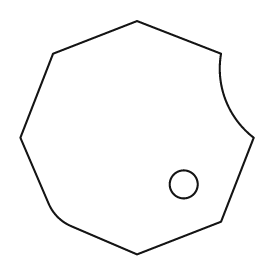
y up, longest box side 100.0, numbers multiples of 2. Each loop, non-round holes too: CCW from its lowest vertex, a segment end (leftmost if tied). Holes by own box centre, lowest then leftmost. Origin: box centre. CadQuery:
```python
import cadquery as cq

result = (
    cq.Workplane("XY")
    .moveTo(0.0, -50.0)
    .lineTo(36.0, -36.0)
    .lineTo(50.0, 0.0)
    .threePointArc((38.0, 16.0), (36.0, 36.0))
    .lineTo(0.0, 50.0)
    .lineTo(-36.0, 36.0)
    .lineTo(-50.0, 0.0)
    .lineTo(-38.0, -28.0)
    .threePointArc((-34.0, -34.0), (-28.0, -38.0))
    .close()
    .moveTo(20.0, -20.0)
    .circle(6.0)
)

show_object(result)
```